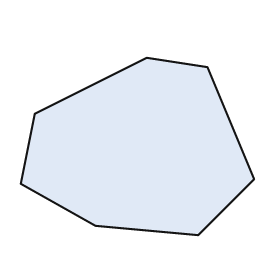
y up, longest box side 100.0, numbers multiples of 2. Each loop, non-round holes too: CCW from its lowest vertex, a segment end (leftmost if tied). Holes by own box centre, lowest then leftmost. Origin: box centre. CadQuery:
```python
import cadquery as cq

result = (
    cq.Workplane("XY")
    .moveTo(26.0, -38.0)
    .lineTo(50.0, -14.0)
    .lineTo(30.0, 34.0)
    .lineTo(4.0, 38.0)
    .lineTo(-44.0, 14.0)
    .lineTo(-50.0, -16.0)
    .lineTo(-18.0, -34.0)
    .close()
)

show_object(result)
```